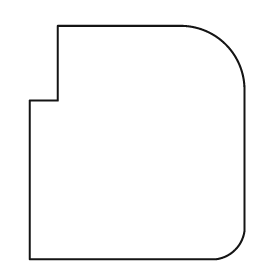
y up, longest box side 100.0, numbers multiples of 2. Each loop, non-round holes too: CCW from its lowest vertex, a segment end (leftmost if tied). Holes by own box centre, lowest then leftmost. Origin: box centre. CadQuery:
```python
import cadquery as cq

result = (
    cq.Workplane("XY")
    .moveTo(-46.0, -50.0)
    .lineTo(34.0, -50.0)
    .threePointArc((42.0, -46.0), (46.0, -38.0))
    .lineTo(46.0, 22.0)
    .threePointArc((38.0, 42.0), (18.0, 50.0))
    .lineTo(-34.0, 50.0)
    .lineTo(-34.0, 18.0)
    .lineTo(-46.0, 18.0)
    .close()
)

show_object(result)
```